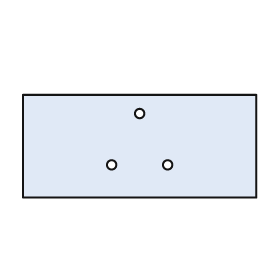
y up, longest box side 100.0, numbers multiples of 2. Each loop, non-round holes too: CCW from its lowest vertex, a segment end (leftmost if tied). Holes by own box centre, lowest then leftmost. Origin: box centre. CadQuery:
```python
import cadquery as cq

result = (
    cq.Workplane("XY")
    .moveTo(-50.0, -22.0)
    .lineTo(50.0, -22.0)
    .lineTo(50.0, 22.0)
    .lineTo(-50.0, 22.0)
    .close()
    .moveTo(-12.0, -8.0)
    .circle(2.0)
    .moveTo(12.0, -8.0)
    .circle(2.0)
    .moveTo(0.0, 14.0)
    .circle(2.0)
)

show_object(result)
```